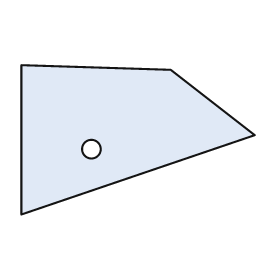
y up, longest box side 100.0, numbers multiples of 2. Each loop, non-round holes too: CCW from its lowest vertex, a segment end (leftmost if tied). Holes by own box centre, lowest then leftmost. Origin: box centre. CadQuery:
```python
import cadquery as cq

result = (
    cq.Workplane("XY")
    .moveTo(-50.0, -32.0)
    .lineTo(50.0, 2.0)
    .lineTo(14.0, 30.0)
    .lineTo(-50.0, 32.0)
    .close()
    .moveTo(-20.0, -4.0)
    .circle(4.0)
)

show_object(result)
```